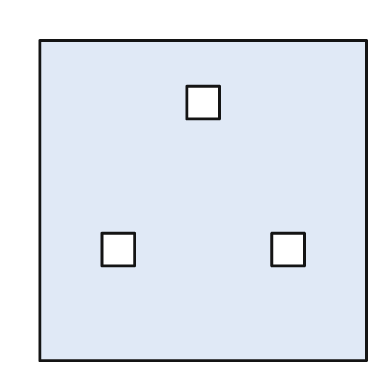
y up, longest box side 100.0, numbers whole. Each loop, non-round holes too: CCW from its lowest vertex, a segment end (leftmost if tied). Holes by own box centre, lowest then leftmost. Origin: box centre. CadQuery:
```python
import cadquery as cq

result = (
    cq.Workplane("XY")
    .moveTo(-50.0, -49.0)
    .lineTo(50.0, -49.0)
    .lineTo(50.0, 49.0)
    .lineTo(-50.0, 49.0)
    .close()
    .moveTo(-31.0, -20.0)
    .lineTo(-21.0, -20.0)
    .lineTo(-21.0, -10.0)
    .lineTo(-31.0, -10.0)
    .close()
    .moveTo(21.0, -20.0)
    .lineTo(31.0, -20.0)
    .lineTo(31.0, -10.0)
    .lineTo(21.0, -10.0)
    .close()
    .moveTo(-5.0, 25.0)
    .lineTo(5.0, 25.0)
    .lineTo(5.0, 35.0)
    .lineTo(-5.0, 35.0)
    .close()
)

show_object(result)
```